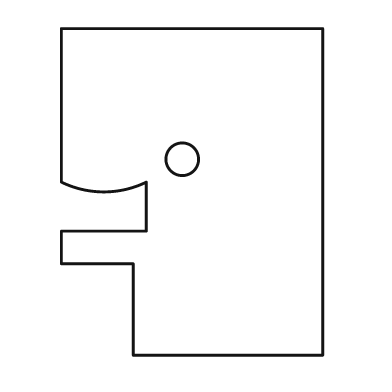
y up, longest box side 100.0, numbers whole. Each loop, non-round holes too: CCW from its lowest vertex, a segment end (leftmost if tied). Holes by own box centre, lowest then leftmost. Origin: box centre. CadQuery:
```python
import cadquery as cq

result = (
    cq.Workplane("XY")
    .moveTo(-18.0, -50.0)
    .lineTo(40.0, -50.0)
    .lineTo(40.0, 50.0)
    .lineTo(-40.0, 50.0)
    .lineTo(-40.0, 3.0)
    .threePointArc((-27.0, 0.0), (-14.0, 3.0))
    .lineTo(-14.0, -12.0)
    .lineTo(-40.0, -12.0)
    .lineTo(-40.0, -22.0)
    .lineTo(-18.0, -22.0)
    .close()
    .moveTo(-3.0, 10.0)
    .circle(5.0)
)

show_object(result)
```